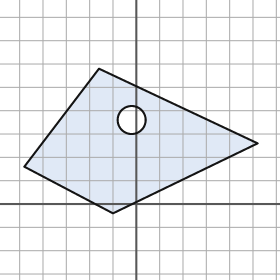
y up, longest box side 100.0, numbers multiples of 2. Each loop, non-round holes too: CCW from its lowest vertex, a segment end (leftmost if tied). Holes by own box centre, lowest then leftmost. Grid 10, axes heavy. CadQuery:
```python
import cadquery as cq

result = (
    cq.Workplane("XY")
    .moveTo(-10.0, -4.0)
    .lineTo(52.0, 26.0)
    .lineTo(-16.0, 58.0)
    .lineTo(-48.0, 16.0)
    .close()
    .moveTo(-2.0, 36.0)
    .circle(6.0)
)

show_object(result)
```